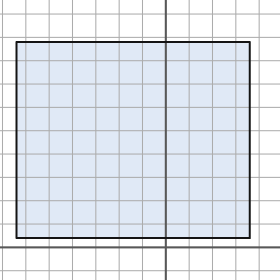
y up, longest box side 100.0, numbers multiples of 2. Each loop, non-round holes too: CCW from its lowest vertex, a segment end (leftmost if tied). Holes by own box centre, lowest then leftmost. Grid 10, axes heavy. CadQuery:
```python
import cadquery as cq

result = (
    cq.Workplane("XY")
    .moveTo(-64.0, 4.0)
    .lineTo(36.0, 4.0)
    .lineTo(36.0, 88.0)
    .lineTo(-64.0, 88.0)
    .close()
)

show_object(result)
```